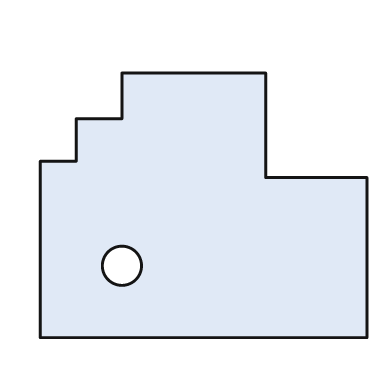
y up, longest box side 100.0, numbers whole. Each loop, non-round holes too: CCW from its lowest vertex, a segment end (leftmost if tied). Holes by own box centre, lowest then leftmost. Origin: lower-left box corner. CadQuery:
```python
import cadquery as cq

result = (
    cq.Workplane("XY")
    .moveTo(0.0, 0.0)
    .lineTo(100.0, 0.0)
    .lineTo(100.0, 49.0)
    .lineTo(69.0, 49.0)
    .lineTo(69.0, 81.0)
    .lineTo(25.0, 81.0)
    .lineTo(25.0, 67.0)
    .lineTo(11.0, 67.0)
    .lineTo(11.0, 54.0)
    .lineTo(0.0, 54.0)
    .close()
    .moveTo(25.0, 22.0)
    .circle(6.0)
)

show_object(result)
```